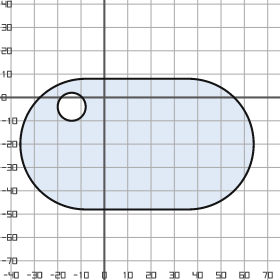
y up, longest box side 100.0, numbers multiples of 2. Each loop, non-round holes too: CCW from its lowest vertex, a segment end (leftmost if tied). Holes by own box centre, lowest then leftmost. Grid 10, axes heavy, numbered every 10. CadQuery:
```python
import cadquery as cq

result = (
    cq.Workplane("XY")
    .moveTo(-8.0, -48.0)
    .lineTo(36.0, -48.0)
    .threePointArc((64.0, -20.0), (36.0, 8.0))
    .lineTo(-8.0, 8.0)
    .threePointArc((-36.0, -20.0), (-8.0, -48.0))
    .close()
    .moveTo(-14.0, -4.0)
    .circle(6.0)
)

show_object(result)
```